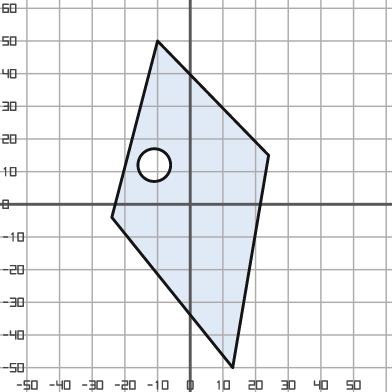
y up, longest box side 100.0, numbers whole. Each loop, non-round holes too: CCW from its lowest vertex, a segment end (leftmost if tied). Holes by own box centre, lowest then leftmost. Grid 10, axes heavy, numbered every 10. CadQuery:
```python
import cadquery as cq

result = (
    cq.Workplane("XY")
    .moveTo(13.0, -50.0)
    .lineTo(24.0, 15.0)
    .lineTo(-10.0, 50.0)
    .lineTo(-24.0, -4.0)
    .close()
    .moveTo(-11.0, 12.0)
    .circle(5.0)
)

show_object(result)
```